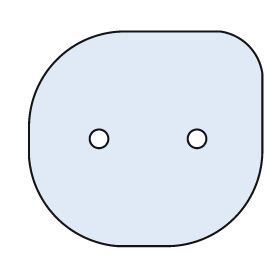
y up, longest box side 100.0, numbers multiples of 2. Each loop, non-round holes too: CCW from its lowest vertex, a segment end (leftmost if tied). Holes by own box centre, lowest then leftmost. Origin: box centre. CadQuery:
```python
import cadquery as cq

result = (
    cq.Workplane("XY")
    .moveTo(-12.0, -46.0)
    .lineTo(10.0, -46.0)
    .threePointArc((38.0, -34.0), (50.0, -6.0))
    .lineTo(50.0, 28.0)
    .threePointArc((44.0, 40.0), (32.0, 46.0))
    .lineTo(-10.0, 46.0)
    .threePointArc((-38.0, 34.0), (-50.0, 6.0))
    .lineTo(-50.0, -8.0)
    .threePointArc((-38.0, -34.0), (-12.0, -46.0))
    .close()
    .moveTo(-20.0, 0.0)
    .circle(4.0)
    .moveTo(22.0, 0.0)
    .circle(4.0)
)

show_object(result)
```